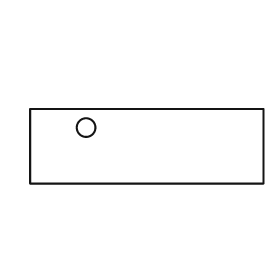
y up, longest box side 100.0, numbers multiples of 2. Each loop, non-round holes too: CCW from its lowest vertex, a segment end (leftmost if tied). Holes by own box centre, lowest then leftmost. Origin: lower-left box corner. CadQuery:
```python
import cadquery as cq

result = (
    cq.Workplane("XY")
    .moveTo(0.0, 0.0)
    .lineTo(100.0, 0.0)
    .lineTo(100.0, 32.0)
    .lineTo(0.0, 32.0)
    .close()
    .moveTo(24.0, 24.0)
    .circle(4.0)
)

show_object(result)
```